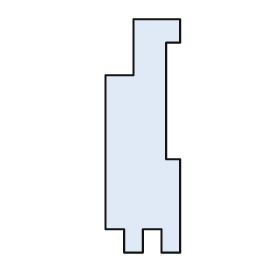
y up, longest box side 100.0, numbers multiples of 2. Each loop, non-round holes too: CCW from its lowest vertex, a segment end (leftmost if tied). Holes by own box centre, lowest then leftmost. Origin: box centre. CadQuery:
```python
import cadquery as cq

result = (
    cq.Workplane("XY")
    .moveTo(-8.0, -50.0)
    .lineTo(0.0, -50.0)
    .lineTo(0.0, -40.0)
    .lineTo(8.0, -40.0)
    .lineTo(8.0, -50.0)
    .lineTo(16.0, -50.0)
    .lineTo(16.0, -10.0)
    .lineTo(10.0, -10.0)
    .lineTo(10.0, 40.0)
    .lineTo(16.0, 40.0)
    .lineTo(16.0, 50.0)
    .lineTo(-4.0, 50.0)
    .lineTo(-4.0, 26.0)
    .lineTo(-16.0, 26.0)
    .lineTo(-16.0, -40.0)
    .lineTo(-8.0, -40.0)
    .close()
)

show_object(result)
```